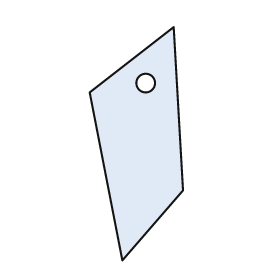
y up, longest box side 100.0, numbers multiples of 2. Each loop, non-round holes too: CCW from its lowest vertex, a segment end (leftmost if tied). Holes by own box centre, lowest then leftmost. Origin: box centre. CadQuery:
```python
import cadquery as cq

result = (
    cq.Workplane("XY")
    .moveTo(-6.0, -50.0)
    .lineTo(20.0, -20.0)
    .lineTo(16.0, 50.0)
    .lineTo(-20.0, 22.0)
    .close()
    .moveTo(4.0, 26.0)
    .circle(4.0)
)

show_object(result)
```